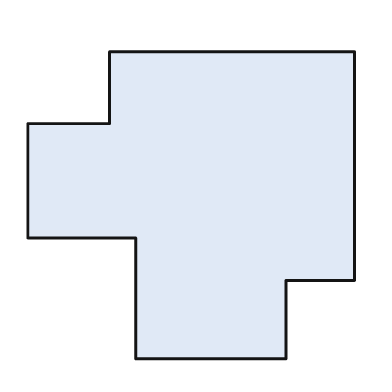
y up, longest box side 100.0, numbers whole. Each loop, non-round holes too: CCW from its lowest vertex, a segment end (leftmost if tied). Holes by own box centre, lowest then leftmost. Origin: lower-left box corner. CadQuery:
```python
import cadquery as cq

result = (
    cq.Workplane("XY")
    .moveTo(33.0, 0.0)
    .lineTo(79.0, 0.0)
    .lineTo(79.0, 24.0)
    .lineTo(100.0, 24.0)
    .lineTo(100.0, 94.0)
    .lineTo(25.0, 94.0)
    .lineTo(25.0, 72.0)
    .lineTo(0.0, 72.0)
    .lineTo(0.0, 37.0)
    .lineTo(33.0, 37.0)
    .close()
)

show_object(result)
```